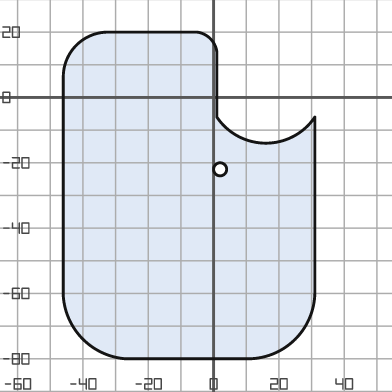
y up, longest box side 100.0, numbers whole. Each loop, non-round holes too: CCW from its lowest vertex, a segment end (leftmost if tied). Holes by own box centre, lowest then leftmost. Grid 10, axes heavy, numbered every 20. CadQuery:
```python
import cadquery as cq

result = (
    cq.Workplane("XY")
    .moveTo(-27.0, -80.0)
    .lineTo(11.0, -80.0)
    .threePointArc((25.0, -74.0), (31.0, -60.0))
    .lineTo(31.0, -6.0)
    .threePointArc((16.0, -14.0), (1.0, -6.0))
    .lineTo(1.0, 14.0)
    .threePointArc((-1.0, 18.0), (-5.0, 20.0))
    .lineTo(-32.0, 20.0)
    .threePointArc((-42.0, 16.0), (-46.0, 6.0))
    .lineTo(-46.0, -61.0)
    .threePointArc((-40.0, -74.0), (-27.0, -80.0))
    .close()
    .moveTo(2.0, -22.0)
    .circle(2.0)
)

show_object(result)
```